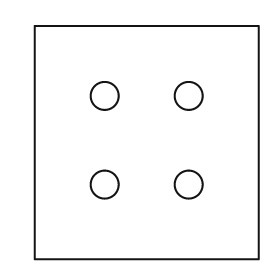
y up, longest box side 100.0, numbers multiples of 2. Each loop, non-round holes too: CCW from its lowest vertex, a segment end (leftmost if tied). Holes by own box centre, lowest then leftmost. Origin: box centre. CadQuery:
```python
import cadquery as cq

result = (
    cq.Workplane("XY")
    .moveTo(-48.0, -50.0)
    .lineTo(48.0, -50.0)
    .lineTo(48.0, 50.0)
    .lineTo(-48.0, 50.0)
    .close()
    .moveTo(-18.0, -18.0)
    .circle(6.0)
    .moveTo(18.0, -18.0)
    .circle(6.0)
    .moveTo(-18.0, 20.0)
    .circle(6.0)
    .moveTo(18.0, 20.0)
    .circle(6.0)
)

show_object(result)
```